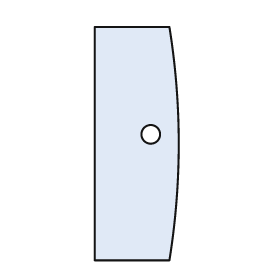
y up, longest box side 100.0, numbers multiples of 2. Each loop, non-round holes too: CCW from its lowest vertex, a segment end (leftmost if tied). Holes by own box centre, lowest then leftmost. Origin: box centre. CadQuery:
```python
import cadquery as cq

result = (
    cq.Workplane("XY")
    .moveTo(-18.0, -50.0)
    .lineTo(14.0, -50.0)
    .threePointArc((18.0, 0.0), (14.0, 50.0))
    .lineTo(-18.0, 50.0)
    .close()
    .moveTo(6.0, 4.0)
    .circle(4.0)
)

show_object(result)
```